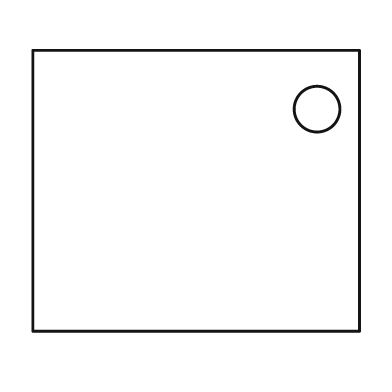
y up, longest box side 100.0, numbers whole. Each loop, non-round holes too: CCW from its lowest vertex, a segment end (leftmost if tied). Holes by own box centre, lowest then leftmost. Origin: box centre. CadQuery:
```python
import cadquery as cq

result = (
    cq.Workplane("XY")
    .moveTo(-50.0, -43.0)
    .lineTo(50.0, -43.0)
    .lineTo(50.0, 43.0)
    .lineTo(-50.0, 43.0)
    .close()
    .moveTo(37.0, 25.0)
    .circle(7.0)
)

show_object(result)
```